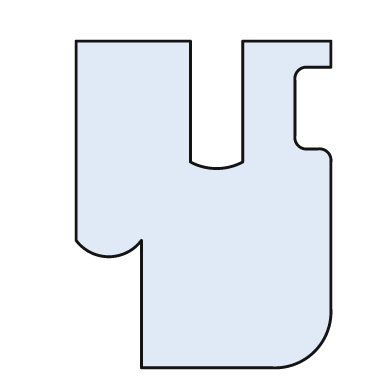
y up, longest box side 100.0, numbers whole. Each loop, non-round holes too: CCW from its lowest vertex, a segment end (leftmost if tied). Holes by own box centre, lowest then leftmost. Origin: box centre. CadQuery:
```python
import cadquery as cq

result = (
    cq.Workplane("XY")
    .moveTo(-19.0, -50.0)
    .lineTo(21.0, -50.0)
    .threePointArc((34.0, -45.0), (39.0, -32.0))
    .lineTo(39.0, 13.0)
    .threePointArc((38.0, 16.0), (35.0, 17.0))
    .lineTo(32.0, 17.0)
    .threePointArc((29.0, 18.0), (28.0, 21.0))
    .lineTo(28.0, 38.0)
    .threePointArc((29.0, 41.0), (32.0, 42.0))
    .lineTo(39.0, 42.0)
    .lineTo(39.0, 50.0)
    .lineTo(12.0, 50.0)
    .lineTo(12.0, 13.0)
    .threePointArc((4.0, 11.0), (-4.0, 13.0))
    .lineTo(-4.0, 50.0)
    .lineTo(-39.0, 50.0)
    .lineTo(-39.0, -11.0)
    .threePointArc((-29.0, -16.0), (-19.0, -11.0))
    .close()
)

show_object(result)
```